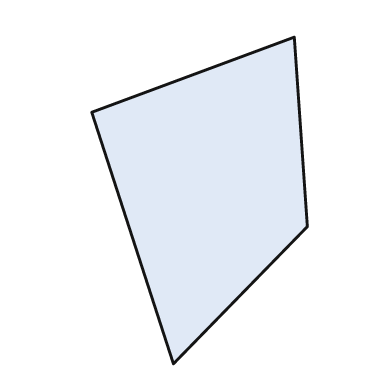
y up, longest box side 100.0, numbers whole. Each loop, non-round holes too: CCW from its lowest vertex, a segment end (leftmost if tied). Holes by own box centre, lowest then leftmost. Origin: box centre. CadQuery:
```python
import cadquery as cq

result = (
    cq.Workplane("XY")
    .moveTo(-8.0, -50.0)
    .lineTo(33.0, -8.0)
    .lineTo(29.0, 50.0)
    .lineTo(-33.0, 27.0)
    .close()
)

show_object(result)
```